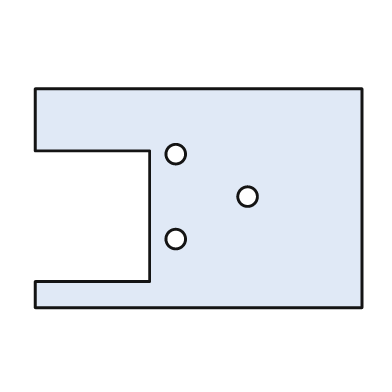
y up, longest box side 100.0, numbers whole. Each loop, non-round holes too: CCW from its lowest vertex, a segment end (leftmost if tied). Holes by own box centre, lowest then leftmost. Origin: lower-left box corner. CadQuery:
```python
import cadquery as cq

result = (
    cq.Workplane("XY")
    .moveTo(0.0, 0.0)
    .lineTo(100.0, 0.0)
    .lineTo(100.0, 67.0)
    .lineTo(0.0, 67.0)
    .lineTo(0.0, 48.0)
    .lineTo(35.0, 48.0)
    .lineTo(35.0, 8.0)
    .lineTo(0.0, 8.0)
    .close()
    .moveTo(43.0, 21.0)
    .circle(3.0)
    .moveTo(65.0, 34.0)
    .circle(3.0)
    .moveTo(43.0, 47.0)
    .circle(3.0)
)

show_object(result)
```